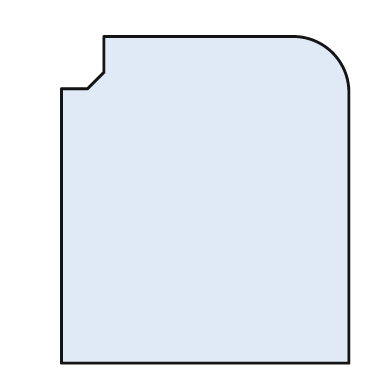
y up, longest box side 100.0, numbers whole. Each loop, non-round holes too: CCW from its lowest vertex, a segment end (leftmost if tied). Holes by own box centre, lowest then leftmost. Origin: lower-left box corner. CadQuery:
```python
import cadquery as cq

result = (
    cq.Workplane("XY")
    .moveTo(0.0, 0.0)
    .lineTo(88.0, 0.0)
    .lineTo(88.0, 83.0)
    .threePointArc((83.0, 95.0), (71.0, 100.0))
    .lineTo(13.0, 100.0)
    .lineTo(13.0, 89.0)
    .lineTo(8.0, 84.0)
    .lineTo(0.0, 84.0)
    .close()
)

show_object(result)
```